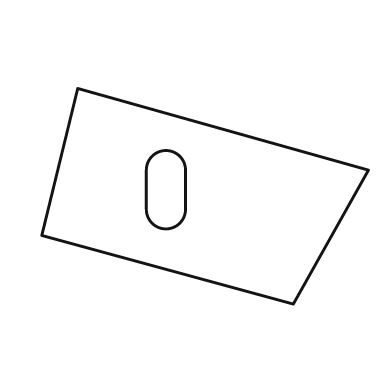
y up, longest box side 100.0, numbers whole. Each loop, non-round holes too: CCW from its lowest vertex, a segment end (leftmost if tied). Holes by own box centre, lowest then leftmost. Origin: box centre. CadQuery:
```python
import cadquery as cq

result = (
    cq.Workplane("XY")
    .moveTo(27.0, -33.0)
    .lineTo(50.0, 8.0)
    .lineTo(-39.0, 33.0)
    .lineTo(-50.0, -12.0)
    .close()
    .moveTo(-18.0, -4.0)
    .threePointArc((-12.0, -10.0), (-6.0, -4.0))
    .lineTo(-6.0, 8.0)
    .threePointArc((-12.0, 14.0), (-18.0, 8.0))
    .close()
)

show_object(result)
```